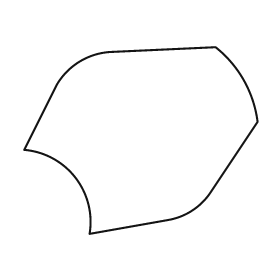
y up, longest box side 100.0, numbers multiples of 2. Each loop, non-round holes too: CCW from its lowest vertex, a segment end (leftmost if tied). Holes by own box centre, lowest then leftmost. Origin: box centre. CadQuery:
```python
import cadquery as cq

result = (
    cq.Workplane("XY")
    .moveTo(-22.0, -40.0)
    .lineTo(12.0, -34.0)
    .threePointArc((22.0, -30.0), (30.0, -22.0))
    .lineTo(50.0, 8.0)
    .threePointArc((44.0, 26.0), (32.0, 40.0))
    .lineTo(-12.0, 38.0)
    .threePointArc((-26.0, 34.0), (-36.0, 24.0))
    .lineTo(-50.0, -4.0)
    .threePointArc((-28.0, -16.0), (-22.0, -40.0))
    .close()
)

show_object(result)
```